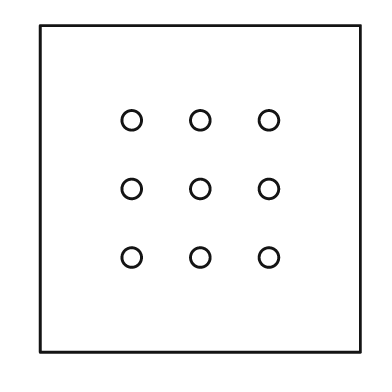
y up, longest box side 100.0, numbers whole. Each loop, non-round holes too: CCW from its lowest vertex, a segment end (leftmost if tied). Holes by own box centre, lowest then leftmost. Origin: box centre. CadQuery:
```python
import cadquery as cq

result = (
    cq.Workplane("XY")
    .moveTo(-49.0, -50.0)
    .lineTo(49.0, -50.0)
    .lineTo(49.0, 50.0)
    .lineTo(-49.0, 50.0)
    .close()
    .moveTo(-21.0, -21.0)
    .circle(3.0)
    .moveTo(0.0, -21.0)
    .circle(3.0)
    .moveTo(21.0, -21.0)
    .circle(3.0)
    .moveTo(-21.0, 0.0)
    .circle(3.0)
    .moveTo(0.0, 0.0)
    .circle(3.0)
    .moveTo(21.0, 0.0)
    .circle(3.0)
    .moveTo(-21.0, 21.0)
    .circle(3.0)
    .moveTo(0.0, 21.0)
    .circle(3.0)
    .moveTo(21.0, 21.0)
    .circle(3.0)
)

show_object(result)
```